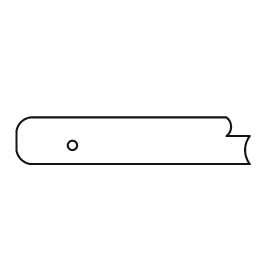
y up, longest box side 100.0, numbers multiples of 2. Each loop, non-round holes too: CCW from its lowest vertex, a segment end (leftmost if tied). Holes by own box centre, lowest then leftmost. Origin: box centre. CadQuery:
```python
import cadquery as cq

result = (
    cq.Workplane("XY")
    .moveTo(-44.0, -10.0)
    .lineTo(50.0, -10.0)
    .threePointArc((48.0, -4.0), (50.0, 2.0))
    .lineTo(40.0, 2.0)
    .threePointArc((42.0, 6.0), (40.0, 10.0))
    .lineTo(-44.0, 10.0)
    .threePointArc((-48.0, 8.0), (-50.0, 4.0))
    .lineTo(-50.0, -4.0)
    .threePointArc((-48.0, -8.0), (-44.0, -10.0))
    .close()
    .moveTo(-26.0, -2.0)
    .circle(2.0)
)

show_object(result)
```